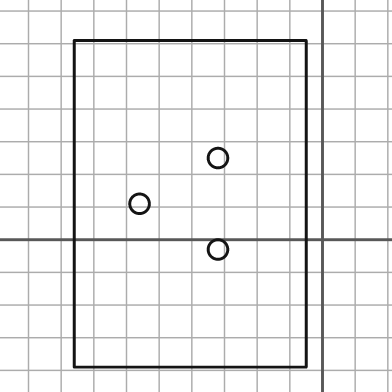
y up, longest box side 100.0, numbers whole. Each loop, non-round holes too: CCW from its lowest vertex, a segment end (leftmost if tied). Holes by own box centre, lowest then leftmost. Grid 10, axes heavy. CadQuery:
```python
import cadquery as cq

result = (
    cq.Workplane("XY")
    .moveTo(-76.0, -39.0)
    .lineTo(-5.0, -39.0)
    .lineTo(-5.0, 61.0)
    .lineTo(-76.0, 61.0)
    .close()
    .moveTo(-32.0, -3.0)
    .circle(3.0)
    .moveTo(-56.0, 11.0)
    .circle(3.0)
    .moveTo(-32.0, 25.0)
    .circle(3.0)
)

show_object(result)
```